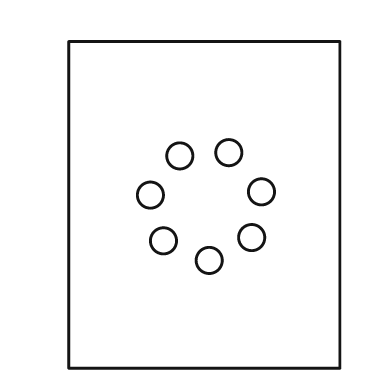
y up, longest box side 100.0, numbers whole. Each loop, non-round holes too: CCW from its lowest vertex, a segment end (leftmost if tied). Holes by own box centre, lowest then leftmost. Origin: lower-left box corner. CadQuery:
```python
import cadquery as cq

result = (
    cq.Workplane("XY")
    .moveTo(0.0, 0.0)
    .lineTo(83.0, 0.0)
    .lineTo(83.0, 100.0)
    .lineTo(0.0, 100.0)
    .close()
    .moveTo(43.0, 33.0)
    .circle(4.0)
    .moveTo(29.0, 39.0)
    .circle(4.0)
    .moveTo(56.0, 40.0)
    .circle(4.0)
    .moveTo(25.0, 53.0)
    .circle(4.0)
    .moveTo(59.0, 54.0)
    .circle(4.0)
    .moveTo(34.0, 65.0)
    .circle(4.0)
    .moveTo(49.0, 66.0)
    .circle(4.0)
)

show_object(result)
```